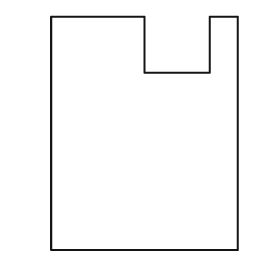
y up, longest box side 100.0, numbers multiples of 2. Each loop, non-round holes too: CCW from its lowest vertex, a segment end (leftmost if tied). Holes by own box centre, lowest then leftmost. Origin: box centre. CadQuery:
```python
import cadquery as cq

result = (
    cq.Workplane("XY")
    .moveTo(-40.0, -50.0)
    .lineTo(40.0, -50.0)
    .lineTo(40.0, 50.0)
    .lineTo(28.0, 50.0)
    .lineTo(28.0, 26.0)
    .lineTo(0.0, 26.0)
    .lineTo(0.0, 50.0)
    .lineTo(-40.0, 50.0)
    .close()
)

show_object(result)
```